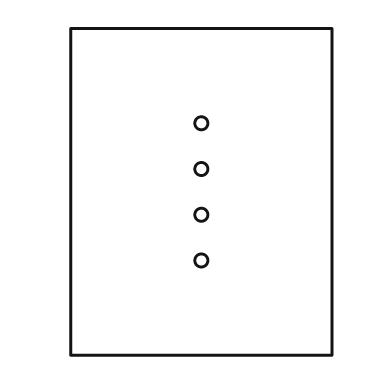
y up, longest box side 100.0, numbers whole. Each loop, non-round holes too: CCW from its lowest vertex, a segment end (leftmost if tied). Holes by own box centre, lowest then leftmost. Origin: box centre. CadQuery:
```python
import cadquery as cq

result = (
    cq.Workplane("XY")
    .moveTo(-40.0, -50.0)
    .lineTo(40.0, -50.0)
    .lineTo(40.0, 50.0)
    .lineTo(-40.0, 50.0)
    .close()
    .moveTo(0.0, -21.0)
    .circle(2.0)
    .moveTo(0.0, -7.0)
    .circle(2.0)
    .moveTo(0.0, 7.0)
    .circle(2.0)
    .moveTo(0.0, 21.0)
    .circle(2.0)
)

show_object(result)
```